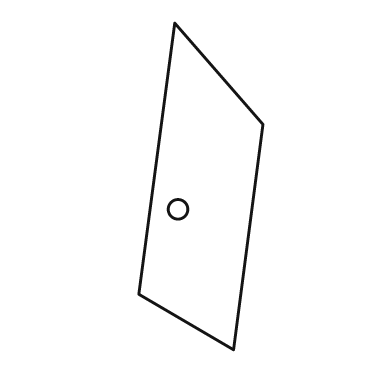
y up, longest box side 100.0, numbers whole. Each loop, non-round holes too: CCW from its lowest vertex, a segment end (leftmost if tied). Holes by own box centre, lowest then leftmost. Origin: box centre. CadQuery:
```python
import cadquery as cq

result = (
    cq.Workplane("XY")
    .moveTo(10.0, -50.0)
    .lineTo(19.0, 19.0)
    .lineTo(-8.0, 50.0)
    .lineTo(-19.0, -33.0)
    .close()
    .moveTo(-7.0, -7.0)
    .circle(3.0)
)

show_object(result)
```